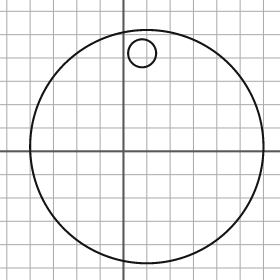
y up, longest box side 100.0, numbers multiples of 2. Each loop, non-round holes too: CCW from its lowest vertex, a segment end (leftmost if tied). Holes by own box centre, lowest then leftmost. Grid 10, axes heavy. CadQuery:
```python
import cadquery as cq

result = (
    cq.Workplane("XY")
    .moveTo(10.0, 2.0)
    .circle(50.0)
    .moveTo(8.0, 42.0)
    .circle(6.0)
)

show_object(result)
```